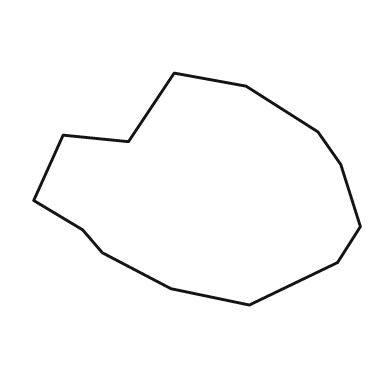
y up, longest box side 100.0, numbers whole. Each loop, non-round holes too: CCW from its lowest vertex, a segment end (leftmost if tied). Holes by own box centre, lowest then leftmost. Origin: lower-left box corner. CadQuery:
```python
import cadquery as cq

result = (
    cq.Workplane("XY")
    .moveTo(66.0, 0.0)
    .lineTo(93.0, 13.0)
    .lineTo(100.0, 24.0)
    .lineTo(94.0, 43.0)
    .lineTo(87.0, 53.0)
    .lineTo(65.0, 67.0)
    .lineTo(43.0, 71.0)
    .lineTo(29.0, 50.0)
    .lineTo(9.0, 52.0)
    .lineTo(0.0, 32.0)
    .lineTo(15.0, 23.0)
    .lineTo(21.0, 16.0)
    .lineTo(42.0, 5.0)
    .close()
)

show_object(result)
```